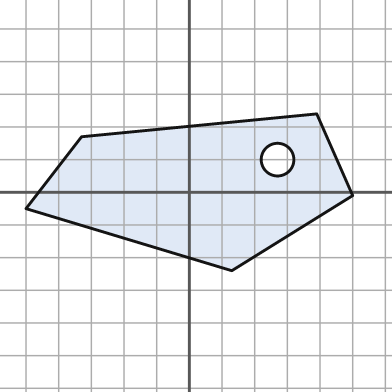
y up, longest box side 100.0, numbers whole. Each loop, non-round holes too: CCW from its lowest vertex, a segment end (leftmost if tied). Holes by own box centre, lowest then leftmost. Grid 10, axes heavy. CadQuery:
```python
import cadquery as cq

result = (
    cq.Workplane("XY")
    .moveTo(13.0, -24.0)
    .lineTo(50.0, -1.0)
    .lineTo(39.0, 24.0)
    .lineTo(-33.0, 17.0)
    .lineTo(-50.0, -5.0)
    .close()
    .moveTo(27.0, 10.0)
    .circle(5.0)
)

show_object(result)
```